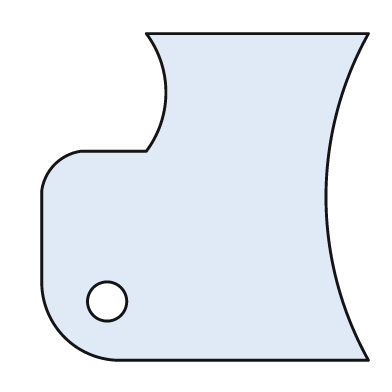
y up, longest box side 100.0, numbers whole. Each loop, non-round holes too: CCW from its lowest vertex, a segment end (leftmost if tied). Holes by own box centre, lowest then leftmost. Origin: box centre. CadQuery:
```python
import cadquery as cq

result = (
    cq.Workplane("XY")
    .moveTo(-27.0, -50.0)
    .lineTo(50.0, -50.0)
    .threePointArc((37.0, 0.0), (50.0, 50.0))
    .lineTo(-18.0, 50.0)
    .threePointArc((-12.0, 32.0), (-18.0, 14.0))
    .lineTo(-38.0, 14.0)
    .threePointArc((-46.0, 10.0), (-50.0, 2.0))
    .lineTo(-50.0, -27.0)
    .threePointArc((-43.0, -43.0), (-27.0, -50.0))
    .close()
    .moveTo(-30.0, -32.0)
    .circle(6.0)
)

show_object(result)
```